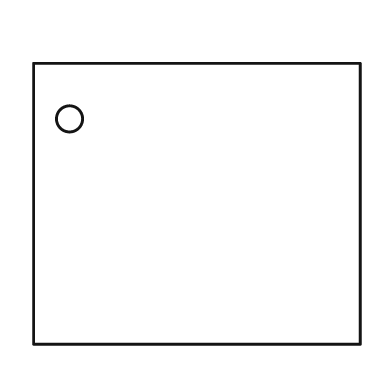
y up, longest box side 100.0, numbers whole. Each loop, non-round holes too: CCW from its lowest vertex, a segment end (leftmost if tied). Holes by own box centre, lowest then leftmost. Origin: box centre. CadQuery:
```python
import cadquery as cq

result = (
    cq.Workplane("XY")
    .moveTo(-50.0, -43.0)
    .lineTo(50.0, -43.0)
    .lineTo(50.0, 43.0)
    .lineTo(-50.0, 43.0)
    .close()
    .moveTo(-39.0, 26.0)
    .circle(4.0)
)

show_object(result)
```